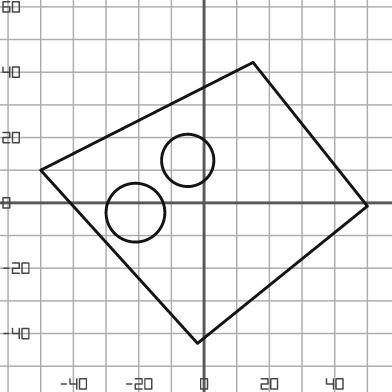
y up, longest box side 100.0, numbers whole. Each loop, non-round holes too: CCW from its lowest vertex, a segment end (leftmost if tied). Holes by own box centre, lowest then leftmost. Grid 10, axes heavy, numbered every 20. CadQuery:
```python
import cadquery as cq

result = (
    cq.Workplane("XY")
    .moveTo(-2.0, -43.0)
    .lineTo(50.0, -1.0)
    .lineTo(15.0, 43.0)
    .lineTo(-50.0, 10.0)
    .close()
    .moveTo(-21.0, -3.0)
    .circle(9.0)
    .moveTo(-5.0, 13.0)
    .circle(8.0)
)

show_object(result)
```